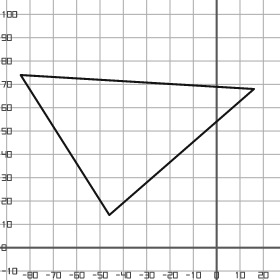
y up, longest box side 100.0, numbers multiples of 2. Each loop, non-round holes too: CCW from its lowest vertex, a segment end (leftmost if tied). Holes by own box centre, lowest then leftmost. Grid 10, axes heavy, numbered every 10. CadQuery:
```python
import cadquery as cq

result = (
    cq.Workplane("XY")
    .moveTo(-46.0, 14.0)
    .lineTo(16.0, 68.0)
    .lineTo(-84.0, 74.0)
    .close()
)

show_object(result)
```